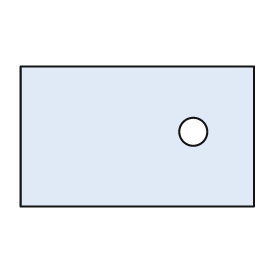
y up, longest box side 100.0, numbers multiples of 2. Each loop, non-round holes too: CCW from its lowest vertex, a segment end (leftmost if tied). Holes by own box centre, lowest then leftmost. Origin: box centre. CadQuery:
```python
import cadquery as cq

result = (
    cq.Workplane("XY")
    .moveTo(-50.0, -30.0)
    .lineTo(50.0, -30.0)
    .lineTo(50.0, 30.0)
    .lineTo(-50.0, 30.0)
    .close()
    .moveTo(24.0, 2.0)
    .circle(6.0)
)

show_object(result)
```